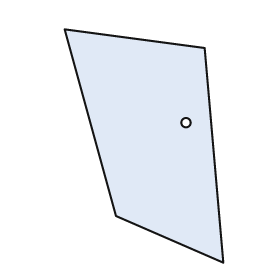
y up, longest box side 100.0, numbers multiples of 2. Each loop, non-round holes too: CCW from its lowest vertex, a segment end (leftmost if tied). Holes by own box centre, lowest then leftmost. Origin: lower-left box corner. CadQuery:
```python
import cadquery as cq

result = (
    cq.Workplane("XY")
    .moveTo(68.0, 0.0)
    .lineTo(60.0, 92.0)
    .lineTo(0.0, 100.0)
    .lineTo(22.0, 20.0)
    .close()
    .moveTo(52.0, 60.0)
    .circle(2.0)
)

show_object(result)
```